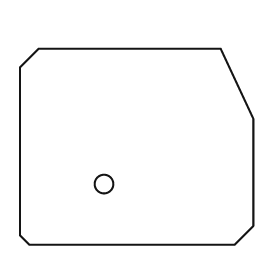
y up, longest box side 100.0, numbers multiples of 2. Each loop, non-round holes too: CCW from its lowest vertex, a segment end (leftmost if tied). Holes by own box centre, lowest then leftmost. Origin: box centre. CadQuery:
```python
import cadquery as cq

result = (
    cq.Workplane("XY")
    .moveTo(-46.0, -42.0)
    .lineTo(42.0, -42.0)
    .lineTo(50.0, -34.0)
    .lineTo(50.0, 12.0)
    .lineTo(36.0, 42.0)
    .lineTo(-42.0, 42.0)
    .lineTo(-50.0, 34.0)
    .lineTo(-50.0, -38.0)
    .close()
    .moveTo(-14.0, -16.0)
    .circle(4.0)
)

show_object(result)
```